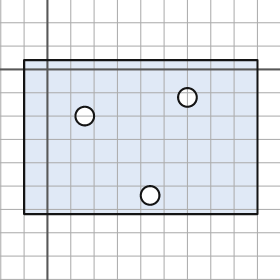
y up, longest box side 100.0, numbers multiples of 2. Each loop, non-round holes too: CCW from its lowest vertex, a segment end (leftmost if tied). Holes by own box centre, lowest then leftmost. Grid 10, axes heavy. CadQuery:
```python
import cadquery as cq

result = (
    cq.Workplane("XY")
    .moveTo(-10.0, -62.0)
    .lineTo(90.0, -62.0)
    .lineTo(90.0, 4.0)
    .lineTo(-10.0, 4.0)
    .close()
    .moveTo(44.0, -54.0)
    .circle(4.0)
    .moveTo(16.0, -20.0)
    .circle(4.0)
    .moveTo(60.0, -12.0)
    .circle(4.0)
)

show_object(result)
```